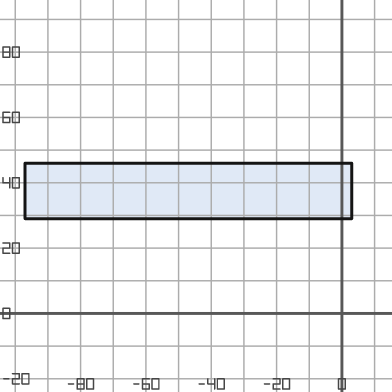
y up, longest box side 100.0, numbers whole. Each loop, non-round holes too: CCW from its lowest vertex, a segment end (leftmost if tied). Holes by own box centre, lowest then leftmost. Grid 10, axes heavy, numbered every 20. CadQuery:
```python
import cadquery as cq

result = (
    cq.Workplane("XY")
    .moveTo(-97.0, 29.0)
    .lineTo(3.0, 29.0)
    .lineTo(3.0, 46.0)
    .lineTo(-97.0, 46.0)
    .close()
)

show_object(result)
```